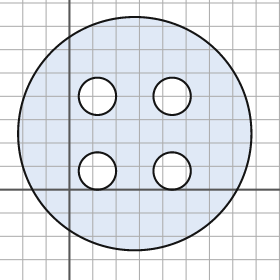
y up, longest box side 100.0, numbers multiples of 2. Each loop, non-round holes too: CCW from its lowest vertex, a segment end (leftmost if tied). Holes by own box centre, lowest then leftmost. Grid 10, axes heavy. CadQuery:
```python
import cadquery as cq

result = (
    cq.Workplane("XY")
    .moveTo(28.0, 24.0)
    .circle(50.0)
    .moveTo(12.0, 8.0)
    .circle(8.0)
    .moveTo(44.0, 8.0)
    .circle(8.0)
    .moveTo(12.0, 40.0)
    .circle(8.0)
    .moveTo(44.0, 40.0)
    .circle(8.0)
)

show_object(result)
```